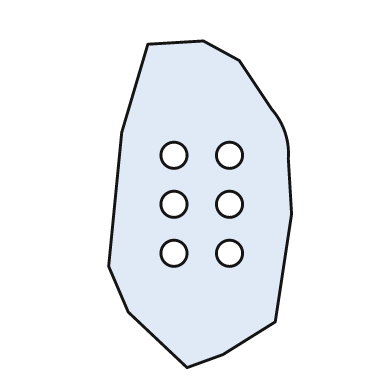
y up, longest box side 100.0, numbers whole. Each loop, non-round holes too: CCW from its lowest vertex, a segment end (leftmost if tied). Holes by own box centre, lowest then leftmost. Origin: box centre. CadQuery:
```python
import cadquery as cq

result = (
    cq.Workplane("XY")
    .moveTo(-4.0, -50.0)
    .lineTo(7.0, -46.0)
    .lineTo(23.0, -36.0)
    .lineTo(28.0, -3.0)
    .lineTo(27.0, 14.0)
    .threePointArc((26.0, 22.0), (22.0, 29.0))
    .lineTo(12.0, 44.0)
    .lineTo(1.0, 50.0)
    .lineTo(-16.0, 49.0)
    .lineTo(-24.0, 22.0)
    .lineTo(-28.0, -19.0)
    .lineTo(-22.0, -33.0)
    .close()
    .moveTo(-8.0, -15.0)
    .circle(4.0)
    .moveTo(9.0, -15.0)
    .circle(4.0)
    .moveTo(-8.0, 0.0)
    .circle(4.0)
    .moveTo(9.0, 0.0)
    .circle(4.0)
    .moveTo(-8.0, 15.0)
    .circle(4.0)
    .moveTo(9.0, 15.0)
    .circle(4.0)
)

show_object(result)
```